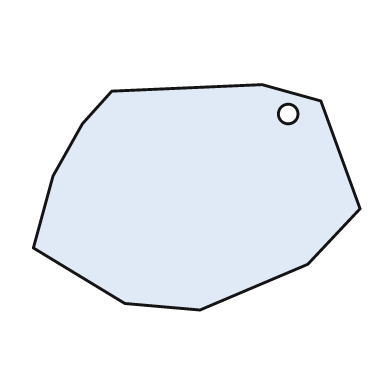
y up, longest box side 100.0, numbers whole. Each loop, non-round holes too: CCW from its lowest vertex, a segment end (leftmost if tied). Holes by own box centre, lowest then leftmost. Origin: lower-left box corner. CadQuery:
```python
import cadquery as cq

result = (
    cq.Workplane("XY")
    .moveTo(51.0, 0.0)
    .lineTo(84.0, 14.0)
    .lineTo(100.0, 31.0)
    .lineTo(88.0, 64.0)
    .lineTo(70.0, 69.0)
    .lineTo(24.0, 67.0)
    .lineTo(15.0, 57.0)
    .lineTo(6.0, 41.0)
    .lineTo(0.0, 19.0)
    .lineTo(28.0, 2.0)
    .close()
    .moveTo(78.0, 60.0)
    .circle(3.0)
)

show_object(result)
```